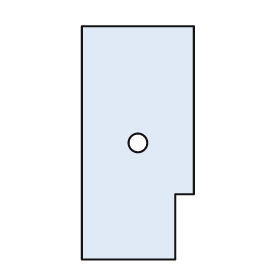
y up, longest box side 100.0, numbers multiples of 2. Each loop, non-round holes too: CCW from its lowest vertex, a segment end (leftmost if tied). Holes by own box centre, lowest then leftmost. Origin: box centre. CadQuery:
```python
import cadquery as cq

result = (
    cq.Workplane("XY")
    .moveTo(-24.0, -50.0)
    .lineTo(16.0, -50.0)
    .lineTo(16.0, -22.0)
    .lineTo(24.0, -22.0)
    .lineTo(24.0, 50.0)
    .lineTo(-24.0, 50.0)
    .close()
    .moveTo(0.0, 0.0)
    .circle(4.0)
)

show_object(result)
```